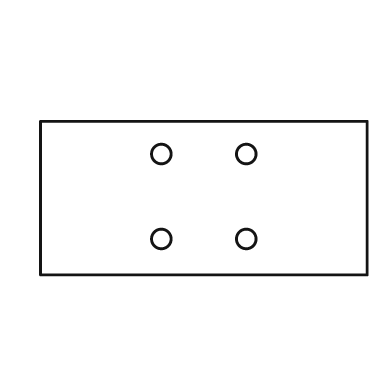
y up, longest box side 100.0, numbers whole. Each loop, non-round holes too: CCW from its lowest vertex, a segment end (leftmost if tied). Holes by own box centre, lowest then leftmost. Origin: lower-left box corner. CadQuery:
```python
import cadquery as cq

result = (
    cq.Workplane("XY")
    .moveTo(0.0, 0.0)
    .lineTo(100.0, 0.0)
    .lineTo(100.0, 47.0)
    .lineTo(0.0, 47.0)
    .close()
    .moveTo(37.0, 11.0)
    .circle(3.0)
    .moveTo(63.0, 11.0)
    .circle(3.0)
    .moveTo(37.0, 37.0)
    .circle(3.0)
    .moveTo(63.0, 37.0)
    .circle(3.0)
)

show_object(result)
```